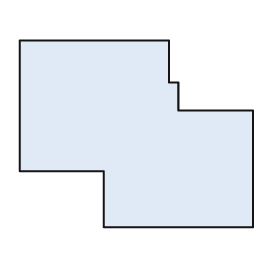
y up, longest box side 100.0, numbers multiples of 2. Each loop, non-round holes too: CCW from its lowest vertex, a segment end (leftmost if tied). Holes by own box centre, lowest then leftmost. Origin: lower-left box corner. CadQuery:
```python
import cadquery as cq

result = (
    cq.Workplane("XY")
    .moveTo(36.0, 0.0)
    .lineTo(100.0, 0.0)
    .lineTo(100.0, 50.0)
    .lineTo(68.0, 50.0)
    .lineTo(68.0, 62.0)
    .lineTo(64.0, 62.0)
    .lineTo(64.0, 80.0)
    .lineTo(0.0, 80.0)
    .lineTo(0.0, 24.0)
    .lineTo(36.0, 24.0)
    .close()
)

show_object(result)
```